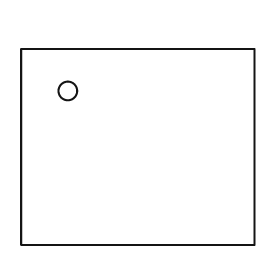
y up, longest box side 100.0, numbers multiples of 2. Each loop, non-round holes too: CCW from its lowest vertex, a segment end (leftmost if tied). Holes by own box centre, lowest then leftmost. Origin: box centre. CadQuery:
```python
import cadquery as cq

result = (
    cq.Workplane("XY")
    .moveTo(-50.0, -42.0)
    .lineTo(50.0, -42.0)
    .lineTo(50.0, 42.0)
    .lineTo(-50.0, 42.0)
    .close()
    .moveTo(-30.0, 24.0)
    .circle(4.0)
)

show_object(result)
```